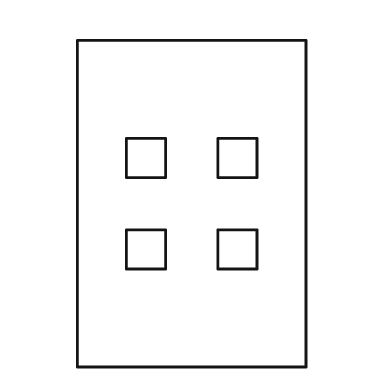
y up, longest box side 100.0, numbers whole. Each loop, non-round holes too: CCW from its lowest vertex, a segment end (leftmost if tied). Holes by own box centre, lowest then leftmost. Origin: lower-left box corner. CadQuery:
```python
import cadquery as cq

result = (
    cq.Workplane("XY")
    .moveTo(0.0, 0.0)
    .lineTo(70.0, 0.0)
    .lineTo(70.0, 100.0)
    .lineTo(0.0, 100.0)
    .close()
    .moveTo(15.0, 30.0)
    .lineTo(27.0, 30.0)
    .lineTo(27.0, 42.0)
    .lineTo(15.0, 42.0)
    .close()
    .moveTo(43.0, 30.0)
    .lineTo(55.0, 30.0)
    .lineTo(55.0, 42.0)
    .lineTo(43.0, 42.0)
    .close()
    .moveTo(15.0, 58.0)
    .lineTo(27.0, 58.0)
    .lineTo(27.0, 70.0)
    .lineTo(15.0, 70.0)
    .close()
    .moveTo(43.0, 58.0)
    .lineTo(55.0, 58.0)
    .lineTo(55.0, 70.0)
    .lineTo(43.0, 70.0)
    .close()
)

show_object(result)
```